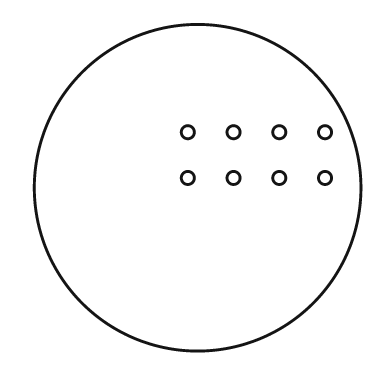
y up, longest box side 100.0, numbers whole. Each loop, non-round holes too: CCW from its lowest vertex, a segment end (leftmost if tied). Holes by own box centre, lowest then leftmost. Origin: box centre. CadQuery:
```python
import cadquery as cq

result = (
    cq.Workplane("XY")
    .moveTo(0.0, 0.0)
    .circle(50.0)
    .moveTo(-3.0, 3.0)
    .circle(2.0)
    .moveTo(11.0, 3.0)
    .circle(2.0)
    .moveTo(25.0, 3.0)
    .circle(2.0)
    .moveTo(39.0, 3.0)
    .circle(2.0)
    .moveTo(-3.0, 17.0)
    .circle(2.0)
    .moveTo(11.0, 17.0)
    .circle(2.0)
    .moveTo(25.0, 17.0)
    .circle(2.0)
    .moveTo(39.0, 17.0)
    .circle(2.0)
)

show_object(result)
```